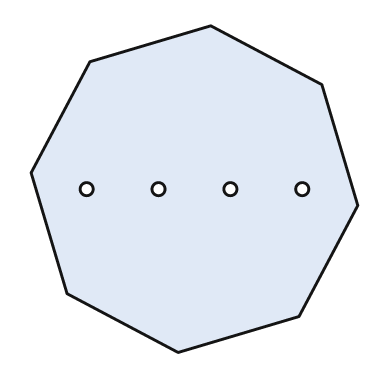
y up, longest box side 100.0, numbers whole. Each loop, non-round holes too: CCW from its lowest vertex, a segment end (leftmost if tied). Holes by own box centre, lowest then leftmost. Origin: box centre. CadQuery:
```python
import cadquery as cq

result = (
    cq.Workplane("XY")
    .moveTo(-5.0, -50.0)
    .lineTo(32.0, -39.0)
    .lineTo(50.0, -5.0)
    .lineTo(39.0, 32.0)
    .lineTo(5.0, 50.0)
    .lineTo(-32.0, 39.0)
    .lineTo(-50.0, 5.0)
    .lineTo(-39.0, -32.0)
    .close()
    .moveTo(-33.0, 0.0)
    .circle(2.0)
    .moveTo(-11.0, 0.0)
    .circle(2.0)
    .moveTo(11.0, 0.0)
    .circle(2.0)
    .moveTo(33.0, 0.0)
    .circle(2.0)
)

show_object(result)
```